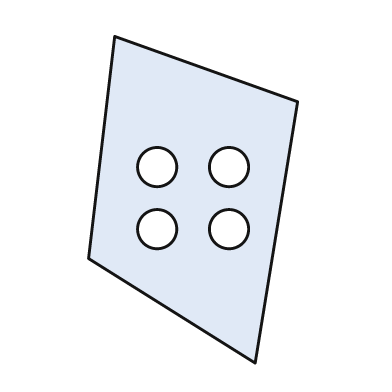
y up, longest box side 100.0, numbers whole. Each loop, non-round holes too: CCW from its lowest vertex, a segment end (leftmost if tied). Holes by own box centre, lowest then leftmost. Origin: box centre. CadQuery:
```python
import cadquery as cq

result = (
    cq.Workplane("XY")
    .moveTo(19.0, -50.0)
    .lineTo(32.0, 30.0)
    .lineTo(-24.0, 50.0)
    .lineTo(-32.0, -18.0)
    .close()
    .moveTo(-11.0, -9.0)
    .circle(6.0)
    .moveTo(11.0, -9.0)
    .circle(6.0)
    .moveTo(-11.0, 10.0)
    .circle(6.0)
    .moveTo(11.0, 10.0)
    .circle(6.0)
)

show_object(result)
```